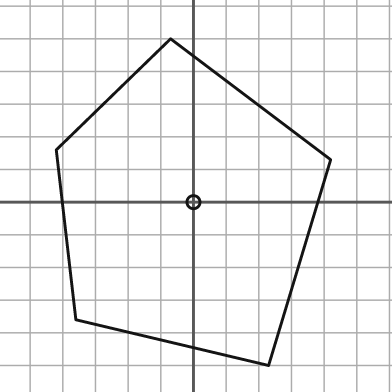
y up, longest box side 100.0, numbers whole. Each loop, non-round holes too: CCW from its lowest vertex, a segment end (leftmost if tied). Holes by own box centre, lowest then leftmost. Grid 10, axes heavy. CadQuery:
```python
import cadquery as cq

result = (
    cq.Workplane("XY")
    .moveTo(23.0, -50.0)
    .lineTo(42.0, 13.0)
    .lineTo(-7.0, 50.0)
    .lineTo(-42.0, 16.0)
    .lineTo(-36.0, -36.0)
    .close()
    .moveTo(0.0, 0.0)
    .circle(2.0)
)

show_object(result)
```